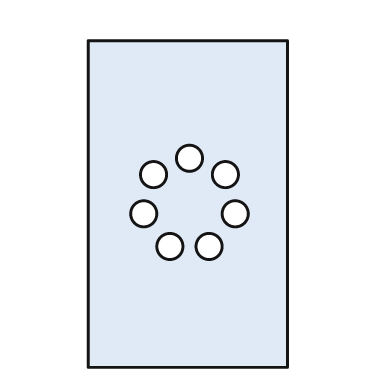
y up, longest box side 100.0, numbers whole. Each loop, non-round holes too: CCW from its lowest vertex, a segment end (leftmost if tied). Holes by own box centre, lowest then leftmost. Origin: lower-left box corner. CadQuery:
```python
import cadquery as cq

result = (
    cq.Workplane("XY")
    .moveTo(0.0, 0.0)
    .lineTo(61.0, 0.0)
    .lineTo(61.0, 100.0)
    .lineTo(0.0, 100.0)
    .close()
    .moveTo(25.0, 37.0)
    .circle(4.0)
    .moveTo(37.0, 37.0)
    .circle(4.0)
    .moveTo(17.0, 47.0)
    .circle(4.0)
    .moveTo(45.0, 47.0)
    .circle(4.0)
    .moveTo(20.0, 59.0)
    .circle(4.0)
    .moveTo(42.0, 59.0)
    .circle(4.0)
    .moveTo(31.0, 64.0)
    .circle(4.0)
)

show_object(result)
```